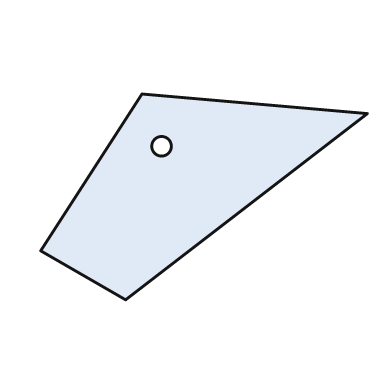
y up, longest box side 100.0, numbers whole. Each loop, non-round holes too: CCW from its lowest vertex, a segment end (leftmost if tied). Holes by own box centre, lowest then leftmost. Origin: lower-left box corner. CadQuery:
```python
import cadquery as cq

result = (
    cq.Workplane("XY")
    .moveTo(26.0, 0.0)
    .lineTo(100.0, 57.0)
    .lineTo(31.0, 63.0)
    .lineTo(0.0, 15.0)
    .close()
    .moveTo(37.0, 47.0)
    .circle(3.0)
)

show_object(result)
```